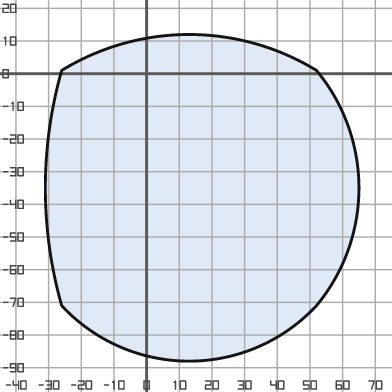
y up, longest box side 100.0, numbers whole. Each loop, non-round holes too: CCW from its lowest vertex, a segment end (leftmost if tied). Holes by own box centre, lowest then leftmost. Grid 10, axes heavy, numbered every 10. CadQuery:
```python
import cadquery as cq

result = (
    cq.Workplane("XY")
    .moveTo(-26.0, -71.0)
    .threePointArc((13.0, -88.0), (52.0, -71.0))
    .threePointArc((65.0, -35.0), (52.0, 1.0))
    .threePointArc((13.0, 12.0), (-26.0, 1.0))
    .threePointArc((-31.0, -35.0), (-26.0, -71.0))
    .close()
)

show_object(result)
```